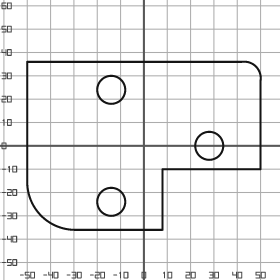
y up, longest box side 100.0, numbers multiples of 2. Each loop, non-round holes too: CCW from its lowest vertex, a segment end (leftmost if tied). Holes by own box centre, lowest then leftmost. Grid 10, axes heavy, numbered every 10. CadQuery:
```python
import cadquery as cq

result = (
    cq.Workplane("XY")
    .moveTo(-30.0, -36.0)
    .lineTo(8.0, -36.0)
    .lineTo(8.0, -10.0)
    .lineTo(50.0, -10.0)
    .lineTo(50.0, 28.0)
    .threePointArc((48.0, 34.0), (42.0, 36.0))
    .lineTo(-50.0, 36.0)
    .lineTo(-50.0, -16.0)
    .threePointArc((-44.0, -30.0), (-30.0, -36.0))
    .close()
    .moveTo(-14.0, -24.0)
    .circle(6.0)
    .moveTo(28.0, 0.0)
    .circle(6.0)
    .moveTo(-14.0, 24.0)
    .circle(6.0)
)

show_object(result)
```